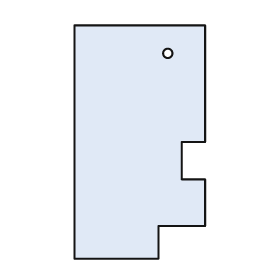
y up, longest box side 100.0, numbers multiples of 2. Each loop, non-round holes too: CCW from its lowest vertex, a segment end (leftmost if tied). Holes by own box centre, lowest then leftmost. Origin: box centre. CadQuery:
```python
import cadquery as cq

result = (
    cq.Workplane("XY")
    .moveTo(-28.0, -50.0)
    .lineTo(8.0, -50.0)
    .lineTo(8.0, -36.0)
    .lineTo(28.0, -36.0)
    .lineTo(28.0, -16.0)
    .lineTo(18.0, -16.0)
    .lineTo(18.0, 0.0)
    .lineTo(28.0, 0.0)
    .lineTo(28.0, 50.0)
    .lineTo(-28.0, 50.0)
    .close()
    .moveTo(12.0, 38.0)
    .circle(2.0)
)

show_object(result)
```